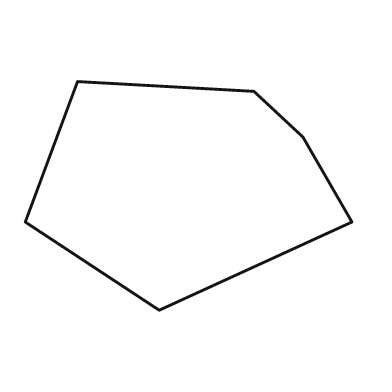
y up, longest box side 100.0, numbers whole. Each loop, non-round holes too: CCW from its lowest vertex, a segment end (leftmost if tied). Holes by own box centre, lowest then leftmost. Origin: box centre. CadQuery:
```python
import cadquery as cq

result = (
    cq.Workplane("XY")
    .moveTo(-9.0, -35.0)
    .lineTo(50.0, -8.0)
    .lineTo(35.0, 18.0)
    .lineTo(20.0, 32.0)
    .lineTo(-34.0, 35.0)
    .lineTo(-50.0, -8.0)
    .close()
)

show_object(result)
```